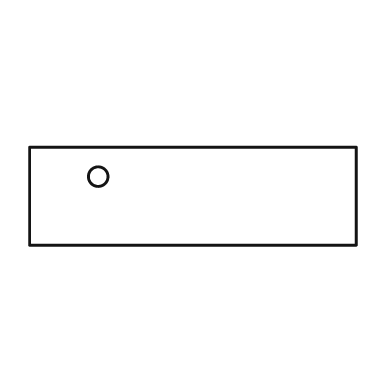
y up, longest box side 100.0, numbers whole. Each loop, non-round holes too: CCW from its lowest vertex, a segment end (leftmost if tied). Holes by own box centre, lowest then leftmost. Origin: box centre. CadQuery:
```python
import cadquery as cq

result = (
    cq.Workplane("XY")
    .moveTo(-50.0, -15.0)
    .lineTo(50.0, -15.0)
    .lineTo(50.0, 15.0)
    .lineTo(-50.0, 15.0)
    .close()
    .moveTo(-29.0, 6.0)
    .circle(3.0)
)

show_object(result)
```